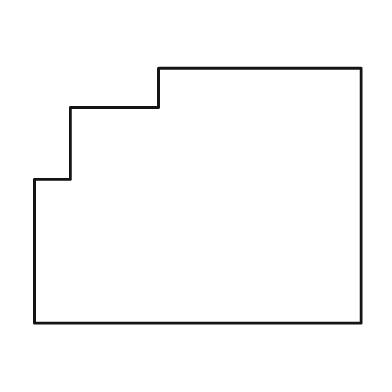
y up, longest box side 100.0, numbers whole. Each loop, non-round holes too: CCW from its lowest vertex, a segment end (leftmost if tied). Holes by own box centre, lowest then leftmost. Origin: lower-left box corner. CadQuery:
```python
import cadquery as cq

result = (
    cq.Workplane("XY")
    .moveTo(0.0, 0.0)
    .lineTo(100.0, 0.0)
    .lineTo(100.0, 78.0)
    .lineTo(38.0, 78.0)
    .lineTo(38.0, 66.0)
    .lineTo(11.0, 66.0)
    .lineTo(11.0, 44.0)
    .lineTo(0.0, 44.0)
    .close()
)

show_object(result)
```